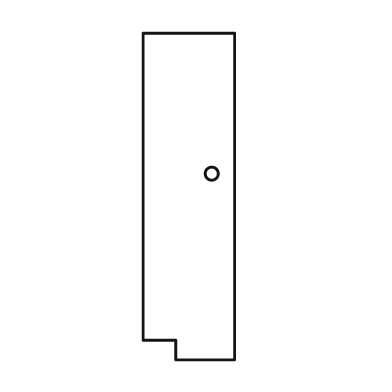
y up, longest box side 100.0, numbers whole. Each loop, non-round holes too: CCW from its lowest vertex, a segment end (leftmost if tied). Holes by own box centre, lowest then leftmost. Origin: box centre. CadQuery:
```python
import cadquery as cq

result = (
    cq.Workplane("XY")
    .moveTo(-4.0, -50.0)
    .lineTo(14.0, -50.0)
    .lineTo(14.0, 50.0)
    .lineTo(-14.0, 50.0)
    .lineTo(-14.0, -44.0)
    .lineTo(-4.0, -44.0)
    .close()
    .moveTo(7.0, 7.0)
    .circle(2.0)
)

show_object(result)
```